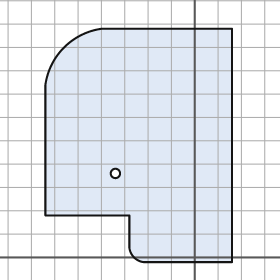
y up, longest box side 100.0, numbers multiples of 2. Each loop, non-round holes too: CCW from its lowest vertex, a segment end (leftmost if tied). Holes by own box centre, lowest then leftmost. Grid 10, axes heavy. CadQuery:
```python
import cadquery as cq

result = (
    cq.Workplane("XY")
    .moveTo(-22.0, -2.0)
    .lineTo(16.0, -2.0)
    .lineTo(16.0, 98.0)
    .lineTo(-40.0, 98.0)
    .threePointArc((-56.0, 90.0), (-64.0, 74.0))
    .lineTo(-64.0, 18.0)
    .lineTo(-28.0, 18.0)
    .lineTo(-28.0, 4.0)
    .threePointArc((-26.0, 0.0), (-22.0, -2.0))
    .close()
    .moveTo(-34.0, 36.0)
    .circle(2.0)
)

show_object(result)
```